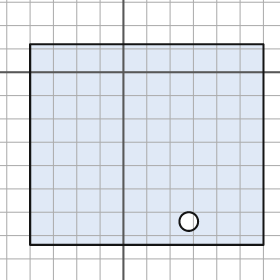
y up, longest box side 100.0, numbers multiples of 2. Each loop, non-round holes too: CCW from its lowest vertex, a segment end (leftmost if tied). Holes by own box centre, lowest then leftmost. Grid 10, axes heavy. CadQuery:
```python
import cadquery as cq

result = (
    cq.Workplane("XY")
    .moveTo(-40.0, -74.0)
    .lineTo(60.0, -74.0)
    .lineTo(60.0, 12.0)
    .lineTo(-40.0, 12.0)
    .close()
    .moveTo(28.0, -64.0)
    .circle(4.0)
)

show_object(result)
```